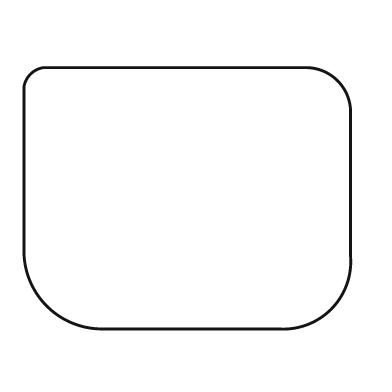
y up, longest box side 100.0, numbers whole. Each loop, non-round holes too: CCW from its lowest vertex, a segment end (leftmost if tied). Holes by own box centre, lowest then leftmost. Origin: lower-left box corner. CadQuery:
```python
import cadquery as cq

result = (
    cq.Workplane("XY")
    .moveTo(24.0, 0.0)
    .lineTo(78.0, 0.0)
    .threePointArc((94.0, 6.0), (100.0, 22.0))
    .lineTo(100.0, 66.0)
    .threePointArc((96.0, 76.0), (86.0, 80.0))
    .lineTo(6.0, 80.0)
    .threePointArc((2.0, 78.0), (0.0, 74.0))
    .lineTo(0.0, 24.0)
    .threePointArc((7.0, 7.0), (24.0, 0.0))
    .close()
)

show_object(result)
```